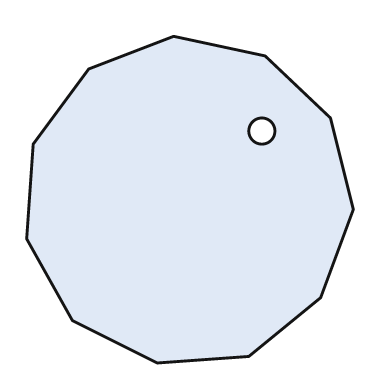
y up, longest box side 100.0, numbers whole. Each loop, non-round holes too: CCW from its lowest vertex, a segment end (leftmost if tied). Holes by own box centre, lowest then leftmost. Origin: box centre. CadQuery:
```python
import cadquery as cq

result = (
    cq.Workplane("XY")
    .moveTo(-10.0, -50.0)
    .lineTo(18.0, -48.0)
    .lineTo(40.0, -30.0)
    .lineTo(50.0, -3.0)
    .lineTo(43.0, 25.0)
    .lineTo(23.0, 44.0)
    .lineTo(-5.0, 50.0)
    .lineTo(-31.0, 40.0)
    .lineTo(-48.0, 17.0)
    .lineTo(-50.0, -12.0)
    .lineTo(-36.0, -37.0)
    .close()
    .moveTo(22.0, 21.0)
    .circle(4.0)
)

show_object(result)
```